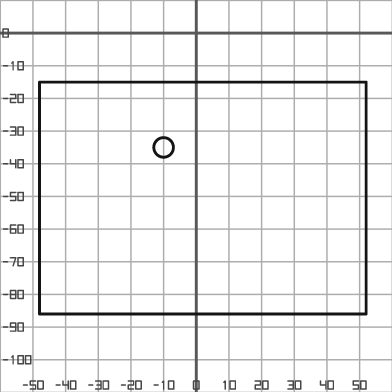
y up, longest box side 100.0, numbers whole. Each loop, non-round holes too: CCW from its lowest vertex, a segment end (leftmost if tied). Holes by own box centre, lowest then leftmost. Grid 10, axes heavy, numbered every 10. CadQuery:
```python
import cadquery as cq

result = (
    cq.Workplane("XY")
    .moveTo(-48.0, -86.0)
    .lineTo(52.0, -86.0)
    .lineTo(52.0, -15.0)
    .lineTo(-48.0, -15.0)
    .close()
    .moveTo(-10.0, -35.0)
    .circle(3.0)
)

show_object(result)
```